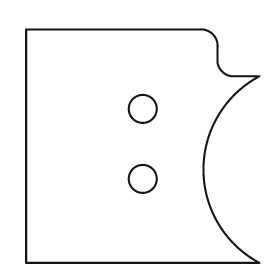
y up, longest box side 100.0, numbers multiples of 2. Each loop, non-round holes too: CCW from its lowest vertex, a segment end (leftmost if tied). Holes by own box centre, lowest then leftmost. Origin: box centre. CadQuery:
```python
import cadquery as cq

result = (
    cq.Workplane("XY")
    .moveTo(-50.0, -50.0)
    .lineTo(50.0, -50.0)
    .threePointArc((26.0, -10.0), (50.0, 30.0))
    .lineTo(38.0, 30.0)
    .threePointArc((34.0, 32.0), (32.0, 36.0))
    .lineTo(32.0, 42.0)
    .threePointArc((30.0, 48.0), (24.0, 50.0))
    .lineTo(-50.0, 50.0)
    .close()
    .moveTo(0.0, -14.0)
    .circle(6.0)
    .moveTo(0.0, 16.0)
    .circle(6.0)
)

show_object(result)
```